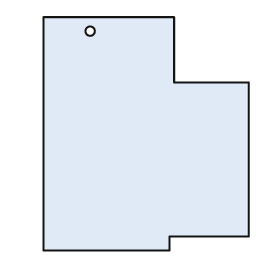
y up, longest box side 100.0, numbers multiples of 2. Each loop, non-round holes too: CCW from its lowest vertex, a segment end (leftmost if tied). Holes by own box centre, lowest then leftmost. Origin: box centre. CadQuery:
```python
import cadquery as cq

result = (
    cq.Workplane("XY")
    .moveTo(-44.0, -50.0)
    .lineTo(10.0, -50.0)
    .lineTo(10.0, -44.0)
    .lineTo(44.0, -44.0)
    .lineTo(44.0, 22.0)
    .lineTo(12.0, 22.0)
    .lineTo(12.0, 50.0)
    .lineTo(-44.0, 50.0)
    .close()
    .moveTo(-24.0, 44.0)
    .circle(2.0)
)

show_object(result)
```